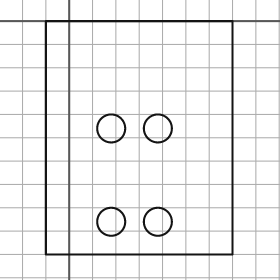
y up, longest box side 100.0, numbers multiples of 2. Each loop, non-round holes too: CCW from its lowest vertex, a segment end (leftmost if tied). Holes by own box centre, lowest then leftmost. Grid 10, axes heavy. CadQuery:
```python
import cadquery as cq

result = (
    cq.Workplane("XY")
    .moveTo(-10.0, -100.0)
    .lineTo(70.0, -100.0)
    .lineTo(70.0, 0.0)
    .lineTo(-10.0, 0.0)
    .close()
    .moveTo(18.0, -86.0)
    .circle(6.0)
    .moveTo(38.0, -86.0)
    .circle(6.0)
    .moveTo(18.0, -46.0)
    .circle(6.0)
    .moveTo(38.0, -46.0)
    .circle(6.0)
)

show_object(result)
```